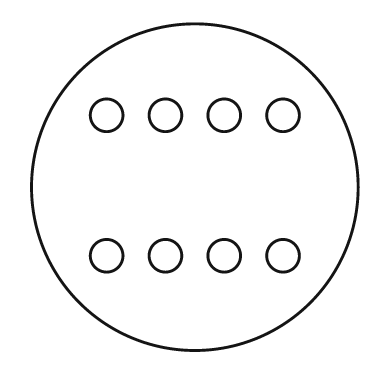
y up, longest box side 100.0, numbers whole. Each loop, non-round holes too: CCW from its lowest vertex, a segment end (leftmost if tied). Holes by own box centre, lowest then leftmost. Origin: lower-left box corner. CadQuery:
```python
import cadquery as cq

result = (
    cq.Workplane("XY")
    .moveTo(50.0, 50.0)
    .circle(50.0)
    .moveTo(23.0, 29.0)
    .circle(5.0)
    .moveTo(41.0, 29.0)
    .circle(5.0)
    .moveTo(59.0, 29.0)
    .circle(5.0)
    .moveTo(77.0, 29.0)
    .circle(5.0)
    .moveTo(23.0, 72.0)
    .circle(5.0)
    .moveTo(41.0, 72.0)
    .circle(5.0)
    .moveTo(59.0, 72.0)
    .circle(5.0)
    .moveTo(77.0, 72.0)
    .circle(5.0)
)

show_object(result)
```